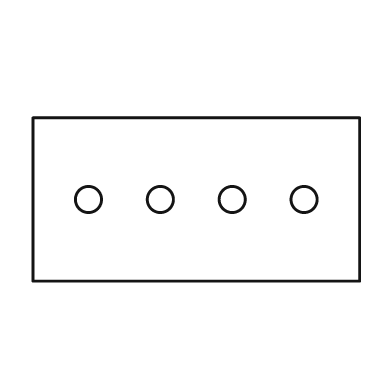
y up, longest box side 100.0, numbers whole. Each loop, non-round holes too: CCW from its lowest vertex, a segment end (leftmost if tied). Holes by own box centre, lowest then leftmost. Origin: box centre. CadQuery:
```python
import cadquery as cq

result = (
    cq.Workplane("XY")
    .moveTo(-50.0, -25.0)
    .lineTo(50.0, -25.0)
    .lineTo(50.0, 25.0)
    .lineTo(-50.0, 25.0)
    .close()
    .moveTo(-33.0, 0.0)
    .circle(4.0)
    .moveTo(-11.0, 0.0)
    .circle(4.0)
    .moveTo(11.0, 0.0)
    .circle(4.0)
    .moveTo(33.0, 0.0)
    .circle(4.0)
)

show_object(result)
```